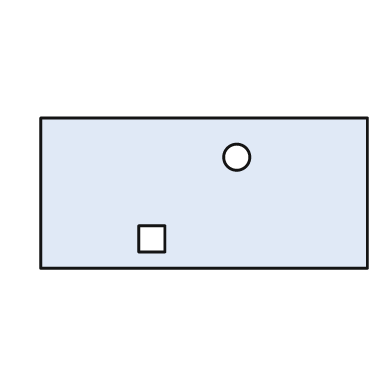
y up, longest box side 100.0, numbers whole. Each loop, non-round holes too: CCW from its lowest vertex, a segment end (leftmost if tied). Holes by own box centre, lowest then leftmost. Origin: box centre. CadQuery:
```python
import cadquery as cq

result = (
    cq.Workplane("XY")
    .moveTo(-50.0, -23.0)
    .lineTo(50.0, -23.0)
    .lineTo(50.0, 23.0)
    .lineTo(-50.0, 23.0)
    .close()
    .moveTo(-20.0, -18.0)
    .lineTo(-12.0, -18.0)
    .lineTo(-12.0, -10.0)
    .lineTo(-20.0, -10.0)
    .close()
    .moveTo(10.0, 11.0)
    .circle(4.0)
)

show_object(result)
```